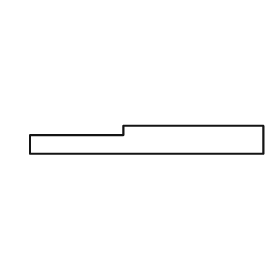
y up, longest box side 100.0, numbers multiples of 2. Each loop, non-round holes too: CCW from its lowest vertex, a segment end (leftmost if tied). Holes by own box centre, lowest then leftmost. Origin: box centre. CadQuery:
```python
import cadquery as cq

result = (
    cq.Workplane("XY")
    .moveTo(-50.0, -6.0)
    .lineTo(50.0, -6.0)
    .lineTo(50.0, 6.0)
    .lineTo(-10.0, 6.0)
    .lineTo(-10.0, 2.0)
    .lineTo(-50.0, 2.0)
    .close()
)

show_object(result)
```